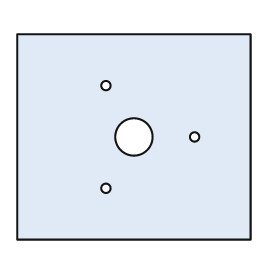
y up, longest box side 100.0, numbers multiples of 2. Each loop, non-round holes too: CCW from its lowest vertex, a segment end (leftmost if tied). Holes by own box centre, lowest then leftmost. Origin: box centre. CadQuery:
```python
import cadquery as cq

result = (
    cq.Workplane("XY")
    .moveTo(-50.0, -44.0)
    .lineTo(50.0, -44.0)
    .lineTo(50.0, 44.0)
    .lineTo(-50.0, 44.0)
    .close()
    .moveTo(-12.0, -22.0)
    .circle(2.0)
    .moveTo(0.0, 0.0)
    .circle(8.0)
    .moveTo(26.0, 0.0)
    .circle(2.0)
    .moveTo(-12.0, 22.0)
    .circle(2.0)
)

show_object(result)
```